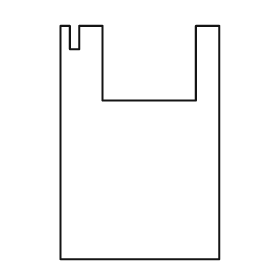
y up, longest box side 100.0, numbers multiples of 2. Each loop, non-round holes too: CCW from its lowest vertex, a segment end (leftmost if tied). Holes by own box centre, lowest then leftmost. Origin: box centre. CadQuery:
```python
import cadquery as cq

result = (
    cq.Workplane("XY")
    .moveTo(-34.0, -50.0)
    .lineTo(34.0, -50.0)
    .lineTo(34.0, 50.0)
    .lineTo(24.0, 50.0)
    .lineTo(24.0, 18.0)
    .lineTo(-16.0, 18.0)
    .lineTo(-16.0, 50.0)
    .lineTo(-26.0, 50.0)
    .lineTo(-26.0, 40.0)
    .lineTo(-30.0, 40.0)
    .lineTo(-30.0, 50.0)
    .lineTo(-34.0, 50.0)
    .close()
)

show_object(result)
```